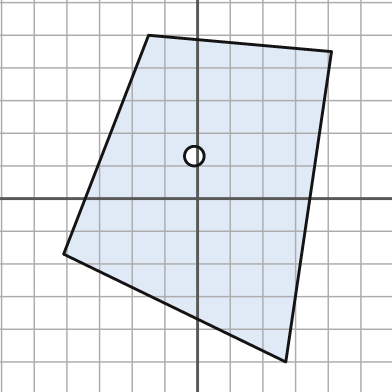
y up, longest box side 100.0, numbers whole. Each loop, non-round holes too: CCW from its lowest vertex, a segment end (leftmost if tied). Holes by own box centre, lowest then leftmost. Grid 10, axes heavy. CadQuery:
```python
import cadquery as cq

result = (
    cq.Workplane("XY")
    .moveTo(27.0, -50.0)
    .lineTo(41.0, 45.0)
    .lineTo(-15.0, 50.0)
    .lineTo(-41.0, -17.0)
    .close()
    .moveTo(-1.0, 13.0)
    .circle(3.0)
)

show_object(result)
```